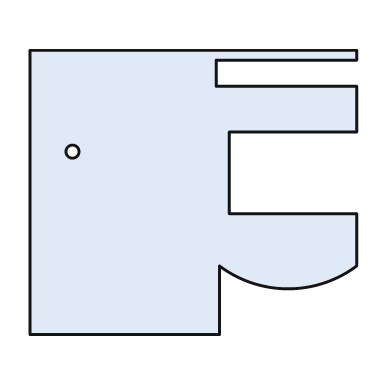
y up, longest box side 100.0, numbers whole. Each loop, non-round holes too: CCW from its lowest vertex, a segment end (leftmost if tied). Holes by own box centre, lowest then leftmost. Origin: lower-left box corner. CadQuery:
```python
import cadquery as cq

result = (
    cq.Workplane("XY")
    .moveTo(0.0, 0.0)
    .lineTo(58.0, 0.0)
    .lineTo(58.0, 21.0)
    .threePointArc((79.0, 14.0), (100.0, 21.0))
    .lineTo(100.0, 37.0)
    .lineTo(61.0, 37.0)
    .lineTo(61.0, 62.0)
    .lineTo(100.0, 62.0)
    .lineTo(100.0, 76.0)
    .lineTo(57.0, 76.0)
    .lineTo(57.0, 84.0)
    .lineTo(100.0, 84.0)
    .lineTo(100.0, 87.0)
    .lineTo(0.0, 87.0)
    .close()
    .moveTo(13.0, 56.0)
    .circle(2.0)
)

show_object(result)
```